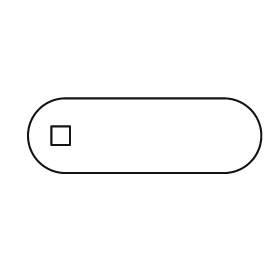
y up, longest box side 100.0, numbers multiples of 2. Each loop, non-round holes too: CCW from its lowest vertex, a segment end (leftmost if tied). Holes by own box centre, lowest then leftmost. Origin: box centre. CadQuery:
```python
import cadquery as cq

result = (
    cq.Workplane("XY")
    .moveTo(-34.0, -16.0)
    .lineTo(34.0, -16.0)
    .threePointArc((50.0, 0.0), (34.0, 16.0))
    .lineTo(-34.0, 16.0)
    .threePointArc((-50.0, 0.0), (-34.0, -16.0))
    .close()
    .moveTo(-40.0, -4.0)
    .lineTo(-32.0, -4.0)
    .lineTo(-32.0, 4.0)
    .lineTo(-40.0, 4.0)
    .close()
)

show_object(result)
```